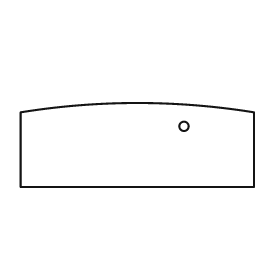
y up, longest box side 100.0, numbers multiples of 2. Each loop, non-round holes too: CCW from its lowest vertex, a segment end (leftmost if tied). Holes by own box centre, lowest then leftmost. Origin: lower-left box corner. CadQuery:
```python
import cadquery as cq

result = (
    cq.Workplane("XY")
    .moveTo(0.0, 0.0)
    .lineTo(100.0, 0.0)
    .lineTo(100.0, 32.0)
    .threePointArc((50.0, 36.0), (0.0, 32.0))
    .close()
    .moveTo(70.0, 26.0)
    .circle(2.0)
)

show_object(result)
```